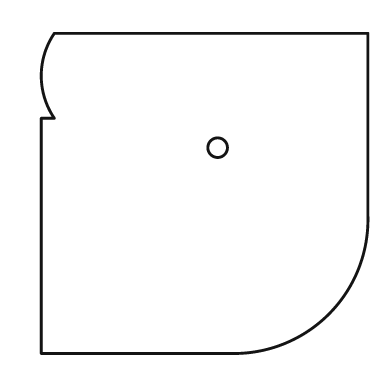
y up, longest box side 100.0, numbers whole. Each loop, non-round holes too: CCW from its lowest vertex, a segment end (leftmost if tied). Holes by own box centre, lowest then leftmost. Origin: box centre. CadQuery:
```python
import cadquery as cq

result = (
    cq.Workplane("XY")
    .moveTo(-50.0, -49.0)
    .lineTo(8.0, -49.0)
    .threePointArc((38.0, -37.0), (50.0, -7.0))
    .lineTo(50.0, 49.0)
    .lineTo(-46.0, 49.0)
    .threePointArc((-50.0, 36.0), (-46.0, 23.0))
    .lineTo(-50.0, 23.0)
    .close()
    .moveTo(4.0, 14.0)
    .circle(3.0)
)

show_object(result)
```